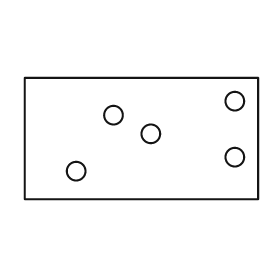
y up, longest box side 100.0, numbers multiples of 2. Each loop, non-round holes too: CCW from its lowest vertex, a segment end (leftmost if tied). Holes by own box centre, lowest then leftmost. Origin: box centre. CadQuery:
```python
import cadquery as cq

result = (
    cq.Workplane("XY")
    .moveTo(-50.0, -26.0)
    .lineTo(50.0, -26.0)
    .lineTo(50.0, 26.0)
    .lineTo(-50.0, 26.0)
    .close()
    .moveTo(-28.0, -14.0)
    .circle(4.0)
    .moveTo(40.0, -8.0)
    .circle(4.0)
    .moveTo(4.0, 2.0)
    .circle(4.0)
    .moveTo(-12.0, 10.0)
    .circle(4.0)
    .moveTo(40.0, 16.0)
    .circle(4.0)
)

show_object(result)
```